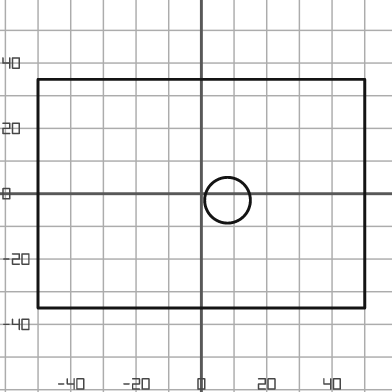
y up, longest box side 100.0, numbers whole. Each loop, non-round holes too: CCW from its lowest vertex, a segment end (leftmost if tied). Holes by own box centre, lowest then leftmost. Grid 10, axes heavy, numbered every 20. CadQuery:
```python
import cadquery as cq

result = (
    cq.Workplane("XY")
    .moveTo(-50.0, -35.0)
    .lineTo(50.0, -35.0)
    .lineTo(50.0, 35.0)
    .lineTo(-50.0, 35.0)
    .close()
    .moveTo(8.0, -2.0)
    .circle(7.0)
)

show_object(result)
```